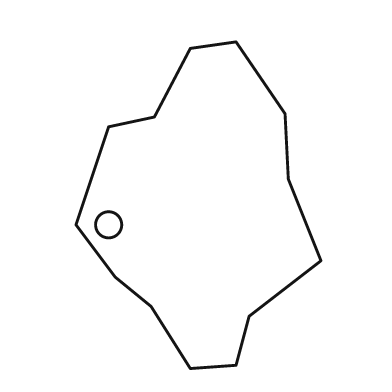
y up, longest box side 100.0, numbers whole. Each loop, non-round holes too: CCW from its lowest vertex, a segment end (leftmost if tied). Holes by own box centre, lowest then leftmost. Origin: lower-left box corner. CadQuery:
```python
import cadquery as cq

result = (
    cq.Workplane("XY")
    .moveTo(35.0, 0.0)
    .lineTo(49.0, 1.0)
    .lineTo(53.0, 16.0)
    .lineTo(75.0, 33.0)
    .lineTo(65.0, 58.0)
    .lineTo(64.0, 78.0)
    .lineTo(49.0, 100.0)
    .lineTo(35.0, 98.0)
    .lineTo(24.0, 77.0)
    .lineTo(10.0, 74.0)
    .lineTo(0.0, 44.0)
    .lineTo(12.0, 28.0)
    .lineTo(23.0, 19.0)
    .close()
    .moveTo(10.0, 44.0)
    .circle(4.0)
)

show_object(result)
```